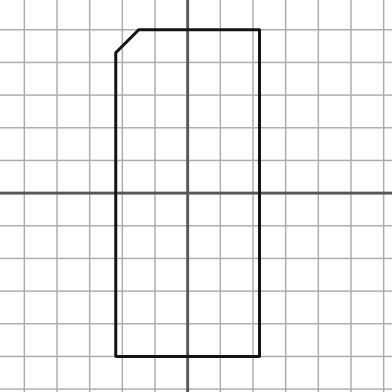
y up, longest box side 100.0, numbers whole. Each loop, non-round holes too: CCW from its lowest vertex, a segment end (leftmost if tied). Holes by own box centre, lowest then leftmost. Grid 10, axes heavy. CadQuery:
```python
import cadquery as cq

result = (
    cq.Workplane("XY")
    .moveTo(-22.0, -50.0)
    .lineTo(22.0, -50.0)
    .lineTo(22.0, 50.0)
    .lineTo(-15.0, 50.0)
    .lineTo(-22.0, 43.0)
    .close()
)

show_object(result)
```